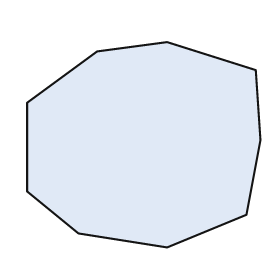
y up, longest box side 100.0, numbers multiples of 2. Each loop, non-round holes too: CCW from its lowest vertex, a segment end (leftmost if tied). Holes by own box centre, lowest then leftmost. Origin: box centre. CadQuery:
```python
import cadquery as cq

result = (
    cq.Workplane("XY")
    .moveTo(10.0, -44.0)
    .lineTo(44.0, -30.0)
    .lineTo(50.0, 2.0)
    .lineTo(48.0, 32.0)
    .lineTo(10.0, 44.0)
    .lineTo(-20.0, 40.0)
    .lineTo(-50.0, 18.0)
    .lineTo(-50.0, -20.0)
    .lineTo(-28.0, -38.0)
    .close()
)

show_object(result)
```